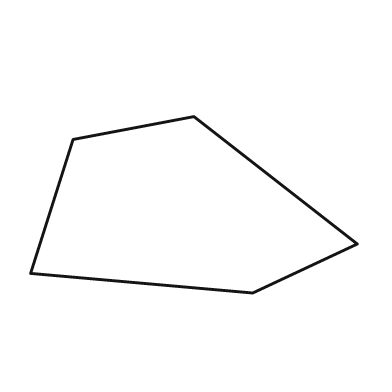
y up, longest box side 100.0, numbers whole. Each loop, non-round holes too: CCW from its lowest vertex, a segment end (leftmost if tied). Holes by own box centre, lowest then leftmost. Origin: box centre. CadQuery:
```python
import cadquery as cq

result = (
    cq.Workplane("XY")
    .moveTo(18.0, -27.0)
    .lineTo(50.0, -12.0)
    .lineTo(0.0, 27.0)
    .lineTo(-37.0, 20.0)
    .lineTo(-50.0, -21.0)
    .close()
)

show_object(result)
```